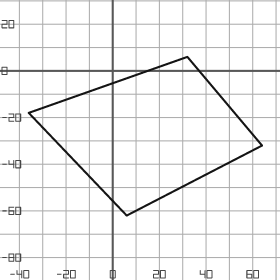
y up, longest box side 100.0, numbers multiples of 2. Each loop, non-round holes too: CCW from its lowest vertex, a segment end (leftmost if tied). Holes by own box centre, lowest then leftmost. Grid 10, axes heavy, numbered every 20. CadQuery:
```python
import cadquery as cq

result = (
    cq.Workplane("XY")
    .moveTo(6.0, -62.0)
    .lineTo(64.0, -32.0)
    .lineTo(32.0, 6.0)
    .lineTo(-36.0, -18.0)
    .close()
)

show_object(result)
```